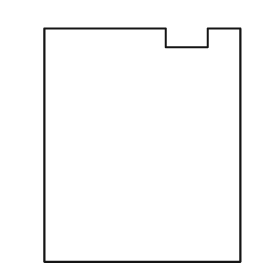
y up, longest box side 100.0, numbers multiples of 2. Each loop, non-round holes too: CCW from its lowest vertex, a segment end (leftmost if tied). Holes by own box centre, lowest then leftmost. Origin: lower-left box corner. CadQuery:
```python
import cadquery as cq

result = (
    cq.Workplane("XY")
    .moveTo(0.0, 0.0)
    .lineTo(84.0, 0.0)
    .lineTo(84.0, 100.0)
    .lineTo(70.0, 100.0)
    .lineTo(70.0, 92.0)
    .lineTo(52.0, 92.0)
    .lineTo(52.0, 100.0)
    .lineTo(0.0, 100.0)
    .close()
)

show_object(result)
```